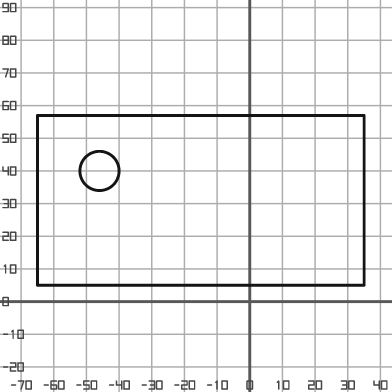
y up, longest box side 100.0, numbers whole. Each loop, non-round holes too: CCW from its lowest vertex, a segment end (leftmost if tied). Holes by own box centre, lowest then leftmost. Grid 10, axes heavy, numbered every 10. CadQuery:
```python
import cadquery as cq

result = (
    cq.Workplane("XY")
    .moveTo(-65.0, 5.0)
    .lineTo(35.0, 5.0)
    .lineTo(35.0, 57.0)
    .lineTo(-65.0, 57.0)
    .close()
    .moveTo(-46.0, 40.0)
    .circle(6.0)
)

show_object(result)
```